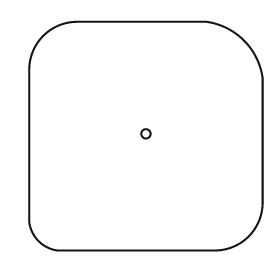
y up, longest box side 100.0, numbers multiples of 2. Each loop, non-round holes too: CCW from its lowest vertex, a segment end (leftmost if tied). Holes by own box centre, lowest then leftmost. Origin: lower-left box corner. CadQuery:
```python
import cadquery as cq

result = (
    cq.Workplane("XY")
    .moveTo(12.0, 0.0)
    .lineTo(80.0, 0.0)
    .threePointArc((94.0, 6.0), (100.0, 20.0))
    .lineTo(100.0, 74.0)
    .threePointArc((92.0, 90.0), (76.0, 98.0))
    .lineTo(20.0, 98.0)
    .threePointArc((6.0, 92.0), (0.0, 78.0))
    .lineTo(0.0, 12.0)
    .threePointArc((4.0, 4.0), (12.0, 0.0))
    .close()
    .moveTo(50.0, 50.0)
    .circle(2.0)
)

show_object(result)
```